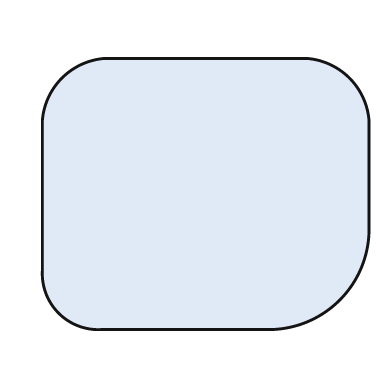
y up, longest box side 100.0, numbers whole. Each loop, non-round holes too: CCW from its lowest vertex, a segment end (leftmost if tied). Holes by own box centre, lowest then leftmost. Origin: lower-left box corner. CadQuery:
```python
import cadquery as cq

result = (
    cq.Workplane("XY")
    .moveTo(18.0, 0.0)
    .lineTo(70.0, 0.0)
    .threePointArc((91.0, 9.0), (100.0, 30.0))
    .lineTo(100.0, 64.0)
    .threePointArc((94.0, 77.0), (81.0, 83.0))
    .lineTo(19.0, 83.0)
    .threePointArc((6.0, 77.0), (0.0, 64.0))
    .lineTo(0.0, 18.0)
    .threePointArc((5.0, 5.0), (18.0, 0.0))
    .close()
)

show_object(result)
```